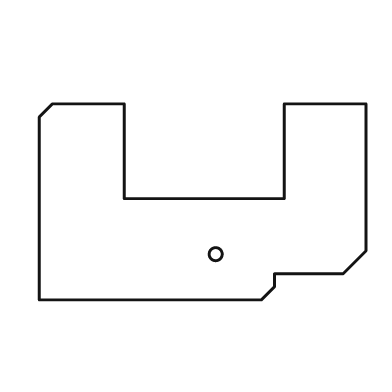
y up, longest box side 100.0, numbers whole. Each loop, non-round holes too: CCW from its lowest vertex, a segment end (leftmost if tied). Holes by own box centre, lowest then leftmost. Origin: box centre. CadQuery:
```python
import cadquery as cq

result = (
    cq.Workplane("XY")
    .moveTo(-50.0, -30.0)
    .lineTo(18.0, -30.0)
    .lineTo(22.0, -26.0)
    .lineTo(22.0, -22.0)
    .lineTo(43.0, -22.0)
    .lineTo(50.0, -15.0)
    .lineTo(50.0, 30.0)
    .lineTo(25.0, 30.0)
    .lineTo(25.0, 1.0)
    .lineTo(-24.0, 1.0)
    .lineTo(-24.0, 30.0)
    .lineTo(-46.0, 30.0)
    .lineTo(-50.0, 26.0)
    .close()
    .moveTo(4.0, -16.0)
    .circle(2.0)
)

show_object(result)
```